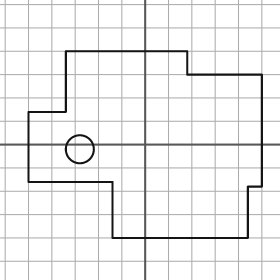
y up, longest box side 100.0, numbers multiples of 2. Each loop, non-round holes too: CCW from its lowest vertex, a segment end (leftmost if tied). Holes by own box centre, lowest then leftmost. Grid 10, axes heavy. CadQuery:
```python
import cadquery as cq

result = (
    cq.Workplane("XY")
    .moveTo(-14.0, -40.0)
    .lineTo(44.0, -40.0)
    .lineTo(44.0, -18.0)
    .lineTo(50.0, -18.0)
    .lineTo(50.0, 30.0)
    .lineTo(18.0, 30.0)
    .lineTo(18.0, 40.0)
    .lineTo(-34.0, 40.0)
    .lineTo(-34.0, 14.0)
    .lineTo(-50.0, 14.0)
    .lineTo(-50.0, -16.0)
    .lineTo(-14.0, -16.0)
    .close()
    .moveTo(-28.0, -2.0)
    .circle(6.0)
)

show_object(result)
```